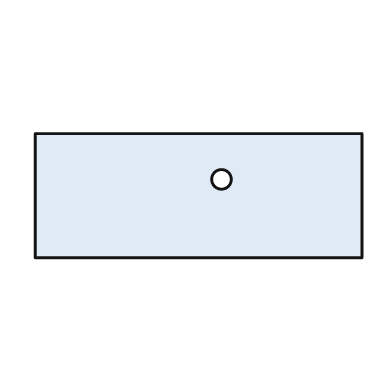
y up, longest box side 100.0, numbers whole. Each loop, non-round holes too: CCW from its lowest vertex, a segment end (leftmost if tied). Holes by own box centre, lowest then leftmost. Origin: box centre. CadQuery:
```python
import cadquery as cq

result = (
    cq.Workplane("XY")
    .moveTo(-50.0, -19.0)
    .lineTo(50.0, -19.0)
    .lineTo(50.0, 19.0)
    .lineTo(-50.0, 19.0)
    .close()
    .moveTo(7.0, 5.0)
    .circle(3.0)
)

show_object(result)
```